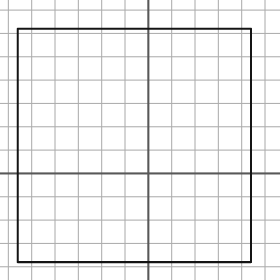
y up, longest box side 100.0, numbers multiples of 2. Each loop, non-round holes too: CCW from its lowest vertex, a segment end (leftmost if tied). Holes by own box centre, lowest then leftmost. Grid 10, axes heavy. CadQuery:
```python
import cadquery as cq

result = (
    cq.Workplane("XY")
    .moveTo(-56.0, -38.0)
    .lineTo(44.0, -38.0)
    .lineTo(44.0, 62.0)
    .lineTo(-56.0, 62.0)
    .close()
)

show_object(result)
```